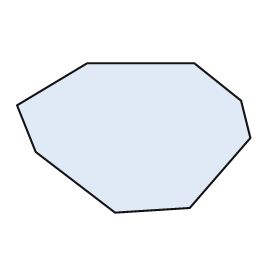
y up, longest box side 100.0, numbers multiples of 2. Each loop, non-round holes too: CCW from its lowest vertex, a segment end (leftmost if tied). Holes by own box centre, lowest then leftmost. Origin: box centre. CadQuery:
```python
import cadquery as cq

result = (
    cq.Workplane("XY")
    .moveTo(-8.0, -32.0)
    .lineTo(24.0, -30.0)
    .lineTo(50.0, 0.0)
    .lineTo(46.0, 16.0)
    .lineTo(26.0, 32.0)
    .lineTo(-20.0, 32.0)
    .lineTo(-50.0, 14.0)
    .lineTo(-42.0, -6.0)
    .close()
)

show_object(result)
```